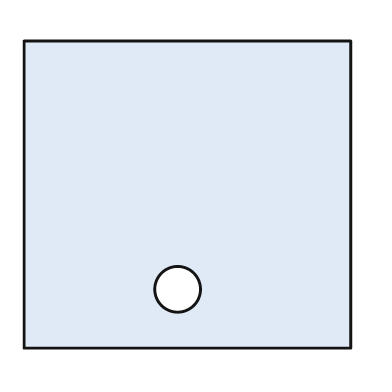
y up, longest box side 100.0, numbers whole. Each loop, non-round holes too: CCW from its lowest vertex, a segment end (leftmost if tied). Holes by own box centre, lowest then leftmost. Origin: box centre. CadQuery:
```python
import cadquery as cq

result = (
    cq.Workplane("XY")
    .moveTo(-50.0, -47.0)
    .lineTo(50.0, -47.0)
    .lineTo(50.0, 47.0)
    .lineTo(-50.0, 47.0)
    .close()
    .moveTo(-3.0, -29.0)
    .circle(7.0)
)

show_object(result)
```